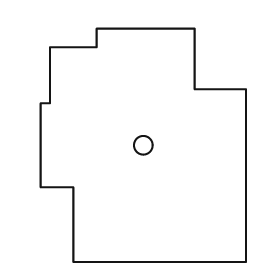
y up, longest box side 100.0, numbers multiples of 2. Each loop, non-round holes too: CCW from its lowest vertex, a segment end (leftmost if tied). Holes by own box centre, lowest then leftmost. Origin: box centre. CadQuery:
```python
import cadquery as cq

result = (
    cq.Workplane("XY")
    .moveTo(-30.0, -50.0)
    .lineTo(44.0, -50.0)
    .lineTo(44.0, 24.0)
    .lineTo(22.0, 24.0)
    .lineTo(22.0, 50.0)
    .lineTo(-20.0, 50.0)
    .lineTo(-20.0, 42.0)
    .lineTo(-40.0, 42.0)
    .lineTo(-40.0, 18.0)
    .lineTo(-44.0, 18.0)
    .lineTo(-44.0, -18.0)
    .lineTo(-30.0, -18.0)
    .close()
    .moveTo(0.0, 0.0)
    .circle(4.0)
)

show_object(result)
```